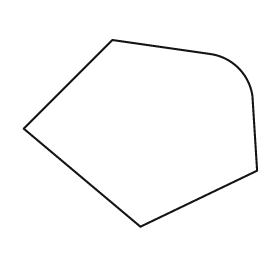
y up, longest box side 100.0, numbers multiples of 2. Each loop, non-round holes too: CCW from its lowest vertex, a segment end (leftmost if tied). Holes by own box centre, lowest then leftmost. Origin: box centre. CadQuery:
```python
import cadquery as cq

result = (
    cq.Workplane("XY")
    .moveTo(0.0, -40.0)
    .lineTo(50.0, -16.0)
    .lineTo(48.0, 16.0)
    .threePointArc((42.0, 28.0), (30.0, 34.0))
    .lineTo(-12.0, 40.0)
    .lineTo(-50.0, 2.0)
    .close()
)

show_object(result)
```